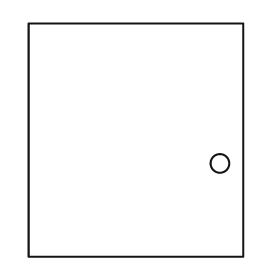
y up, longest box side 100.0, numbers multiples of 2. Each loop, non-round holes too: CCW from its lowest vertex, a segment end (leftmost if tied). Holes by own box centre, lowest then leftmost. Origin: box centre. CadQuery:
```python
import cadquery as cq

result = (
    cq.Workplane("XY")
    .moveTo(-46.0, -50.0)
    .lineTo(46.0, -50.0)
    .lineTo(46.0, 50.0)
    .lineTo(-46.0, 50.0)
    .close()
    .moveTo(36.0, -10.0)
    .circle(4.0)
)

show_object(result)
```